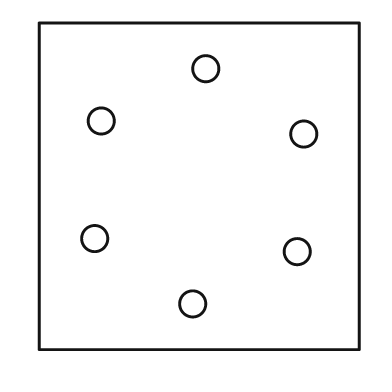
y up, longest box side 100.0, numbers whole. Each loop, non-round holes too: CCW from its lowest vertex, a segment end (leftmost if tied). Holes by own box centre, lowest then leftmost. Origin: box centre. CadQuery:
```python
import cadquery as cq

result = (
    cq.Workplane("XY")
    .moveTo(-49.0, -50.0)
    .lineTo(49.0, -50.0)
    .lineTo(49.0, 50.0)
    .lineTo(-49.0, 50.0)
    .close()
    .moveTo(-2.0, -36.0)
    .circle(4.0)
    .moveTo(30.0, -20.0)
    .circle(4.0)
    .moveTo(-32.0, -16.0)
    .circle(4.0)
    .moveTo(32.0, 16.0)
    .circle(4.0)
    .moveTo(-30.0, 20.0)
    .circle(4.0)
    .moveTo(2.0, 36.0)
    .circle(4.0)
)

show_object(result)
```